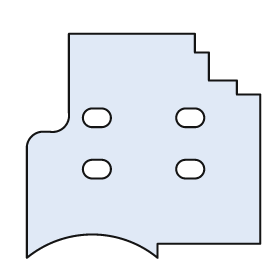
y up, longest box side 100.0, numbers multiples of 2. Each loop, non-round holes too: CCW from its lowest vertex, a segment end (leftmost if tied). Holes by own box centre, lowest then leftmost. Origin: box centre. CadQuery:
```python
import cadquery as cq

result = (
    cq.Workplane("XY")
    .moveTo(-50.0, -48.0)
    .threePointArc((-22.0, -38.0), (6.0, -48.0))
    .lineTo(6.0, -42.0)
    .lineTo(50.0, -42.0)
    .lineTo(50.0, 22.0)
    .lineTo(40.0, 22.0)
    .lineTo(40.0, 28.0)
    .lineTo(28.0, 28.0)
    .lineTo(28.0, 40.0)
    .lineTo(22.0, 40.0)
    .lineTo(22.0, 48.0)
    .lineTo(-32.0, 48.0)
    .lineTo(-32.0, 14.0)
    .threePointArc((-34.0, 8.0), (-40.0, 6.0))
    .lineTo(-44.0, 6.0)
    .threePointArc((-48.0, 4.0), (-50.0, 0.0))
    .close()
    .moveTo(-22.0, -14.0)
    .lineTo(-18.0, -14.0)
    .threePointArc((-14.0, -10.0), (-18.0, -6.0))
    .lineTo(-22.0, -6.0)
    .threePointArc((-26.0, -10.0), (-22.0, -14.0))
    .close()
    .moveTo(18.0, -14.0)
    .lineTo(22.0, -14.0)
    .threePointArc((26.0, -10.0), (22.0, -6.0))
    .lineTo(18.0, -6.0)
    .threePointArc((14.0, -10.0), (18.0, -14.0))
    .close()
    .moveTo(-22.0, 8.0)
    .lineTo(-18.0, 8.0)
    .threePointArc((-14.0, 12.0), (-18.0, 16.0))
    .lineTo(-22.0, 16.0)
    .threePointArc((-26.0, 12.0), (-22.0, 8.0))
    .close()
    .moveTo(18.0, 8.0)
    .lineTo(22.0, 8.0)
    .threePointArc((26.0, 12.0), (22.0, 16.0))
    .lineTo(18.0, 16.0)
    .threePointArc((14.0, 12.0), (18.0, 8.0))
    .close()
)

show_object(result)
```